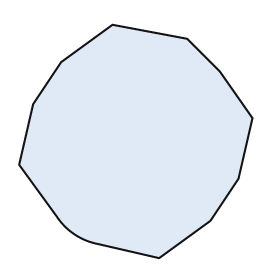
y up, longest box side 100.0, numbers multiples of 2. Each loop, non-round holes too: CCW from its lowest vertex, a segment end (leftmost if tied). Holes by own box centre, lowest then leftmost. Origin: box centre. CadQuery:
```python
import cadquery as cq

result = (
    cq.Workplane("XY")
    .moveTo(10.0, -50.0)
    .lineTo(32.0, -34.0)
    .lineTo(44.0, -16.0)
    .lineTo(50.0, 10.0)
    .lineTo(36.0, 30.0)
    .lineTo(22.0, 44.0)
    .lineTo(-10.0, 50.0)
    .lineTo(-32.0, 34.0)
    .lineTo(-44.0, 16.0)
    .lineTo(-50.0, -10.0)
    .lineTo(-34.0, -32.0)
    .threePointArc((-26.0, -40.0), (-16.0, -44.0))
    .close()
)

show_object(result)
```